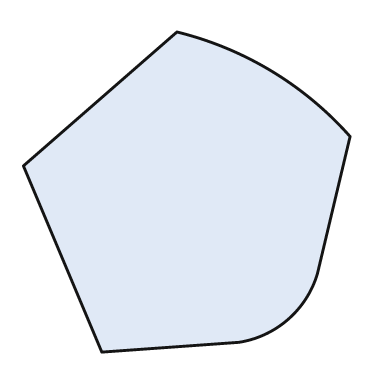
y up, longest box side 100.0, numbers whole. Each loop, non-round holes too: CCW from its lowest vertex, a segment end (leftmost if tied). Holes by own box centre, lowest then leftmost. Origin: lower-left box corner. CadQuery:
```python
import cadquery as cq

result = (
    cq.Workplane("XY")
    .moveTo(24.0, 0.0)
    .lineTo(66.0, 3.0)
    .threePointArc((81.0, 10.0), (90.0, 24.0))
    .lineTo(100.0, 66.0)
    .threePointArc((76.0, 86.0), (47.0, 98.0))
    .lineTo(0.0, 57.0)
    .close()
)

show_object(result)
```